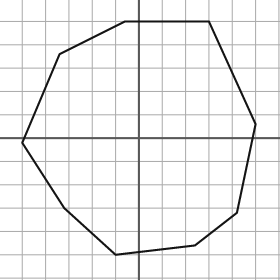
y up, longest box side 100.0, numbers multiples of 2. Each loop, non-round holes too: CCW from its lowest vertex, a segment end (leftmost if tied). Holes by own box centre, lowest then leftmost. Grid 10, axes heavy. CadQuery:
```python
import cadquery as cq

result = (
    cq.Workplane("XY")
    .moveTo(-10.0, -50.0)
    .lineTo(24.0, -46.0)
    .lineTo(42.0, -32.0)
    .lineTo(50.0, 6.0)
    .lineTo(30.0, 50.0)
    .lineTo(-6.0, 50.0)
    .lineTo(-34.0, 36.0)
    .lineTo(-50.0, -2.0)
    .lineTo(-32.0, -30.0)
    .close()
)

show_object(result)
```